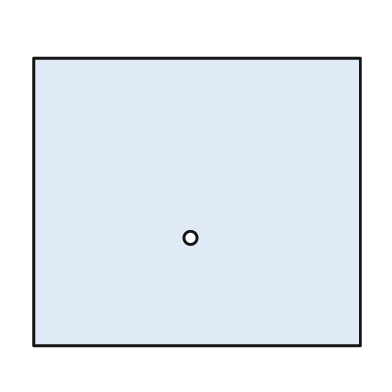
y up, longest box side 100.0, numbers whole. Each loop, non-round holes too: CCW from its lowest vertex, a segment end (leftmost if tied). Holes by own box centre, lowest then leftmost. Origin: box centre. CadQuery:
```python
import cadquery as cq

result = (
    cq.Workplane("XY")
    .moveTo(-50.0, -44.0)
    .lineTo(50.0, -44.0)
    .lineTo(50.0, 44.0)
    .lineTo(-50.0, 44.0)
    .close()
    .moveTo(-2.0, -11.0)
    .circle(2.0)
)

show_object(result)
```